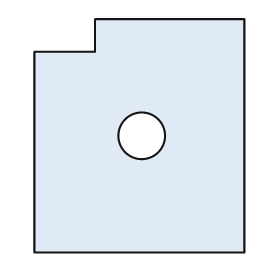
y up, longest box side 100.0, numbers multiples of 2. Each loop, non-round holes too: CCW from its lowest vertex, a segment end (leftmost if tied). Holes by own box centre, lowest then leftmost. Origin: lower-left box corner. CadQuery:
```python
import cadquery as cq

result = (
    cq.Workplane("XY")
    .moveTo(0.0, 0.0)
    .lineTo(90.0, 0.0)
    .lineTo(90.0, 100.0)
    .lineTo(26.0, 100.0)
    .lineTo(26.0, 86.0)
    .lineTo(0.0, 86.0)
    .close()
    .moveTo(46.0, 50.0)
    .circle(10.0)
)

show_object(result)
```